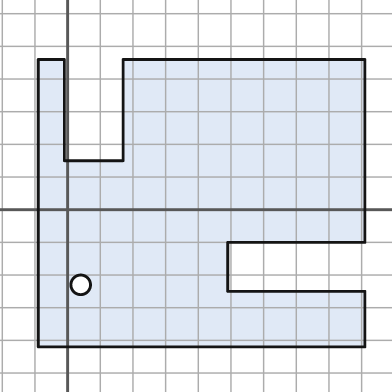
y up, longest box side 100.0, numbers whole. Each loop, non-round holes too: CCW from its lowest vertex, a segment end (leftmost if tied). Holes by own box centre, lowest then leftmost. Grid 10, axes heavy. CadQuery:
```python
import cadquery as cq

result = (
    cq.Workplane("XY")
    .moveTo(-9.0, -42.0)
    .lineTo(91.0, -42.0)
    .lineTo(91.0, -25.0)
    .lineTo(49.0, -25.0)
    .lineTo(49.0, -10.0)
    .lineTo(91.0, -10.0)
    .lineTo(91.0, 46.0)
    .lineTo(17.0, 46.0)
    .lineTo(17.0, 15.0)
    .lineTo(-1.0, 15.0)
    .lineTo(-1.0, 46.0)
    .lineTo(-9.0, 46.0)
    .close()
    .moveTo(4.0, -23.0)
    .circle(3.0)
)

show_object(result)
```